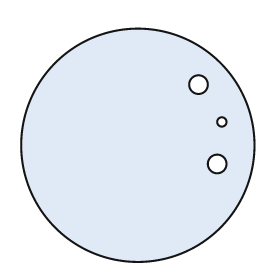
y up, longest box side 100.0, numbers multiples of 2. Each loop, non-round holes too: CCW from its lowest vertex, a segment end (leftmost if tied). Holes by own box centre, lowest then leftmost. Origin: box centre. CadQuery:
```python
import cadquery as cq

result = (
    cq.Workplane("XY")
    .moveTo(0.0, 0.0)
    .circle(50.0)
    .moveTo(34.0, -8.0)
    .circle(4.0)
    .moveTo(36.0, 10.0)
    .circle(2.0)
    .moveTo(26.0, 26.0)
    .circle(4.0)
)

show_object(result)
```